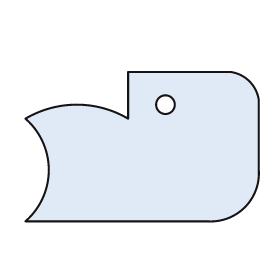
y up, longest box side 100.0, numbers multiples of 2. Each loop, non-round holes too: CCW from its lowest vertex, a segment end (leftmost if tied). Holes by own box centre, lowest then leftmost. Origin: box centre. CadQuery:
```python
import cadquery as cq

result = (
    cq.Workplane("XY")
    .moveTo(-50.0, -32.0)
    .lineTo(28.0, -32.0)
    .threePointArc((44.0, -26.0), (50.0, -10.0))
    .lineTo(50.0, 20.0)
    .threePointArc((46.0, 28.0), (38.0, 32.0))
    .lineTo(-6.0, 32.0)
    .lineTo(-6.0, 12.0)
    .threePointArc((-28.0, 18.0), (-50.0, 12.0))
    .threePointArc((-40.0, -10.0), (-50.0, -32.0))
    .close()
    .moveTo(10.0, 18.0)
    .circle(4.0)
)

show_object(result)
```